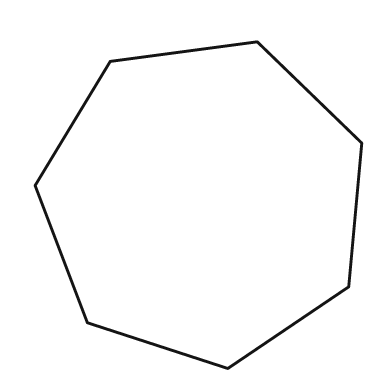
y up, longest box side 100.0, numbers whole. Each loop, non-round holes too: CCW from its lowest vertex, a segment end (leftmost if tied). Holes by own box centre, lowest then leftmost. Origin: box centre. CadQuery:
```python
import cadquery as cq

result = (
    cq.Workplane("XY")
    .moveTo(9.0, -50.0)
    .lineTo(46.0, -25.0)
    .lineTo(50.0, 19.0)
    .lineTo(18.0, 50.0)
    .lineTo(-27.0, 44.0)
    .lineTo(-50.0, 6.0)
    .lineTo(-34.0, -36.0)
    .close()
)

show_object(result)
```